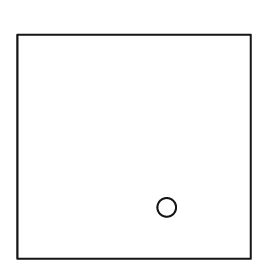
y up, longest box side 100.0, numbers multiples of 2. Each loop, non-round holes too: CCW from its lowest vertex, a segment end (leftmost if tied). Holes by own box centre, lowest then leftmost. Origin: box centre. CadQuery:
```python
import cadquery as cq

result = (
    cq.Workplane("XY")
    .moveTo(-50.0, -48.0)
    .lineTo(50.0, -48.0)
    .lineTo(50.0, 48.0)
    .lineTo(-50.0, 48.0)
    .close()
    .moveTo(14.0, -26.0)
    .circle(4.0)
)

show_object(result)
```